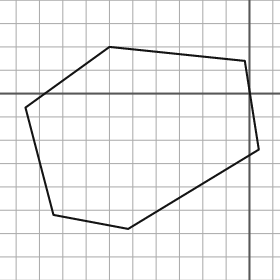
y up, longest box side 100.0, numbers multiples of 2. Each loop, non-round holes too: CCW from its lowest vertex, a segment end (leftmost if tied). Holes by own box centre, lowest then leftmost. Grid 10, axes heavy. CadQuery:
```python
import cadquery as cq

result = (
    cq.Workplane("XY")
    .moveTo(-52.0, -58.0)
    .lineTo(4.0, -24.0)
    .lineTo(-2.0, 14.0)
    .lineTo(-60.0, 20.0)
    .lineTo(-96.0, -6.0)
    .lineTo(-84.0, -52.0)
    .close()
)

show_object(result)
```